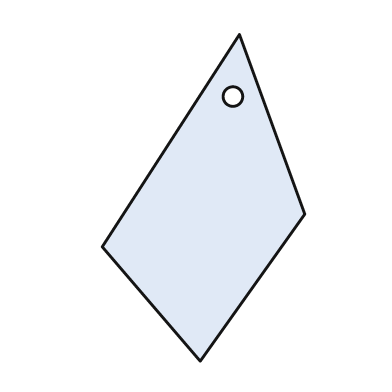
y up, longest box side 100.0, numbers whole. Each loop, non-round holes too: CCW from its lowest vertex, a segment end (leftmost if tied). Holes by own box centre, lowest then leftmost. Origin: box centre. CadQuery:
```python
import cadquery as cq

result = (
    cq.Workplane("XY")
    .moveTo(-1.0, -50.0)
    .lineTo(31.0, -5.0)
    .lineTo(11.0, 50.0)
    .lineTo(-31.0, -15.0)
    .close()
    .moveTo(9.0, 31.0)
    .circle(3.0)
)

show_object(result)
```